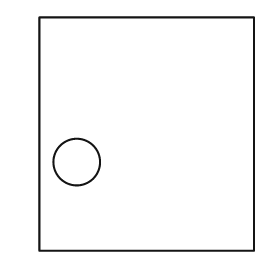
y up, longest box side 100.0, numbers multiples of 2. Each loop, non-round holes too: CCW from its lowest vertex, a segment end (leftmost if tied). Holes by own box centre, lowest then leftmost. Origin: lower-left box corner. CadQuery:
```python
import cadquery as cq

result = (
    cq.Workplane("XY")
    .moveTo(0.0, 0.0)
    .lineTo(92.0, 0.0)
    .lineTo(92.0, 100.0)
    .lineTo(0.0, 100.0)
    .close()
    .moveTo(16.0, 38.0)
    .circle(10.0)
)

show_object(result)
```